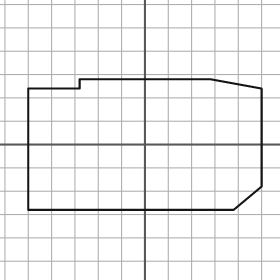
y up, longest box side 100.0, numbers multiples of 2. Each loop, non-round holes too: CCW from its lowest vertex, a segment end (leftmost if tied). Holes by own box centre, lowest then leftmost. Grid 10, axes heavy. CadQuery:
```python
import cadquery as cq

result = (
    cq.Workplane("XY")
    .moveTo(-50.0, -28.0)
    .lineTo(38.0, -28.0)
    .lineTo(50.0, -18.0)
    .lineTo(50.0, 24.0)
    .lineTo(28.0, 28.0)
    .lineTo(-28.0, 28.0)
    .lineTo(-28.0, 24.0)
    .lineTo(-50.0, 24.0)
    .close()
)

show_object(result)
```